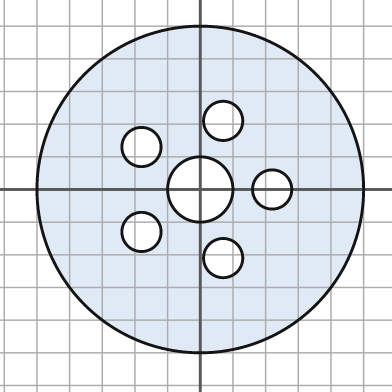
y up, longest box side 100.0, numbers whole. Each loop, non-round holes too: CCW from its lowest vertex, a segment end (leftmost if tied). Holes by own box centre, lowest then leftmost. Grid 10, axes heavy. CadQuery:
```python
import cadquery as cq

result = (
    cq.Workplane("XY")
    .moveTo(0.0, 0.0)
    .circle(50.0)
    .moveTo(7.0, -21.0)
    .circle(6.0)
    .moveTo(-18.0, -13.0)
    .circle(6.0)
    .moveTo(0.0, 0.0)
    .circle(10.0)
    .moveTo(22.0, 0.0)
    .circle(6.0)
    .moveTo(-18.0, 13.0)
    .circle(6.0)
    .moveTo(7.0, 21.0)
    .circle(6.0)
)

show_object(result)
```